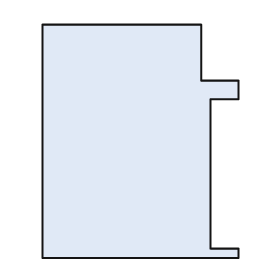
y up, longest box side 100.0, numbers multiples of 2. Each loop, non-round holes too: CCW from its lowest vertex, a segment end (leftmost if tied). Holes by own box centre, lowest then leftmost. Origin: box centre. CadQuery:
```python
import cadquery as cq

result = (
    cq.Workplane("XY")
    .moveTo(-42.0, -50.0)
    .lineTo(42.0, -50.0)
    .lineTo(42.0, -46.0)
    .lineTo(30.0, -46.0)
    .lineTo(30.0, 18.0)
    .lineTo(42.0, 18.0)
    .lineTo(42.0, 26.0)
    .lineTo(26.0, 26.0)
    .lineTo(26.0, 50.0)
    .lineTo(-42.0, 50.0)
    .close()
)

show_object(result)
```